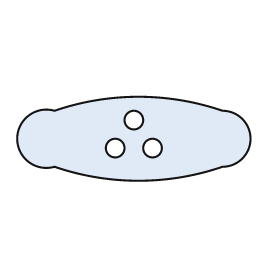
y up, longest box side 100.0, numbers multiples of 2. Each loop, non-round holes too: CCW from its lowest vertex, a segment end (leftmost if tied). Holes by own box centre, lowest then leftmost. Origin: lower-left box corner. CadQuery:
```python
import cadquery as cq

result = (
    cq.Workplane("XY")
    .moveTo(16.0, 6.0)
    .threePointArc((52.0, 0.0), (88.0, 6.0))
    .threePointArc((100.0, 18.0), (88.0, 30.0))
    .threePointArc((52.0, 36.0), (16.0, 30.0))
    .threePointArc((0.0, 18.0), (16.0, 6.0))
    .close()
    .moveTo(42.0, 14.0)
    .circle(4.0)
    .moveTo(58.0, 14.0)
    .circle(4.0)
    .moveTo(50.0, 26.0)
    .circle(4.0)
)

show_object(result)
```